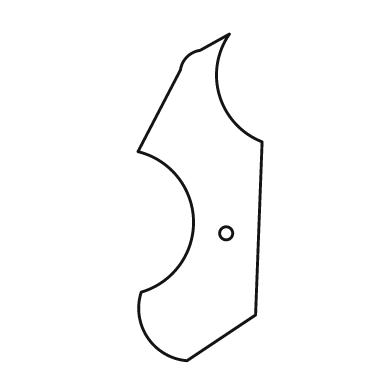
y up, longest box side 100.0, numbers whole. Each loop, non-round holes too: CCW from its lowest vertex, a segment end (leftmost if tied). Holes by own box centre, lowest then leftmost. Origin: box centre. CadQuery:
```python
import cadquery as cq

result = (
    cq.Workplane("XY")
    .moveTo(-4.0, -50.0)
    .lineTo(17.0, -36.0)
    .lineTo(19.0, 17.0)
    .threePointArc((6.0, 31.0), (9.0, 50.0))
    .lineTo(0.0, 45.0)
    .threePointArc((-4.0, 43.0), (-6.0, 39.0))
    .lineTo(-19.0, 14.0)
    .threePointArc((-2.0, -7.0), (-18.0, -29.0))
    .threePointArc((-16.0, -43.0), (-4.0, -50.0))
    .close()
    .moveTo(8.0, -11.0)
    .circle(2.0)
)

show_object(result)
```